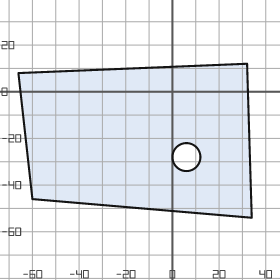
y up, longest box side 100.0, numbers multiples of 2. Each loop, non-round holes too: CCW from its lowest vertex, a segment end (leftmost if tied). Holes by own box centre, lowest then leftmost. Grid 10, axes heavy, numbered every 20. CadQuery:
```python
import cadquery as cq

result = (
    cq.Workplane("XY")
    .moveTo(34.0, -54.0)
    .lineTo(32.0, 12.0)
    .lineTo(-66.0, 8.0)
    .lineTo(-60.0, -46.0)
    .close()
    .moveTo(6.0, -28.0)
    .circle(6.0)
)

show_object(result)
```